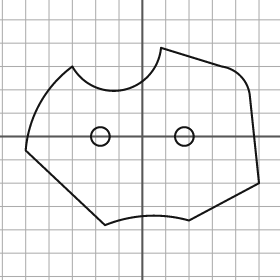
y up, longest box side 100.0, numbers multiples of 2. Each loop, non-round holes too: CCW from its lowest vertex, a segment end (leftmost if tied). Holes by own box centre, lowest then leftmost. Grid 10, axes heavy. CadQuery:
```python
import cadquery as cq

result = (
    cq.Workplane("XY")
    .moveTo(-16.0, -38.0)
    .threePointArc((2.0, -34.0), (20.0, -36.0))
    .lineTo(50.0, -20.0)
    .lineTo(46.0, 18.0)
    .threePointArc((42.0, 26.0), (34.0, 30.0))
    .lineTo(8.0, 38.0)
    .threePointArc((-8.0, 20.0), (-30.0, 30.0))
    .threePointArc((-44.0, 14.0), (-50.0, -6.0))
    .close()
    .moveTo(-18.0, 0.0)
    .circle(4.0)
    .moveTo(18.0, 0.0)
    .circle(4.0)
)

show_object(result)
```